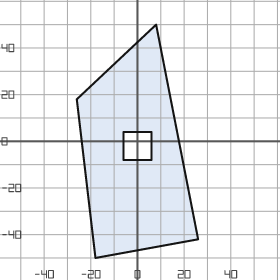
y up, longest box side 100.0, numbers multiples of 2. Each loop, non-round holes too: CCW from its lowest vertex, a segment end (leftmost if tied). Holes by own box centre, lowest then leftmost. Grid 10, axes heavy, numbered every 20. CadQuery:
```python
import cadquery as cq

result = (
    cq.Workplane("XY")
    .moveTo(-18.0, -50.0)
    .lineTo(26.0, -42.0)
    .lineTo(8.0, 50.0)
    .lineTo(-26.0, 18.0)
    .close()
    .moveTo(-6.0, -8.0)
    .lineTo(6.0, -8.0)
    .lineTo(6.0, 4.0)
    .lineTo(-6.0, 4.0)
    .close()
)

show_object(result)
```